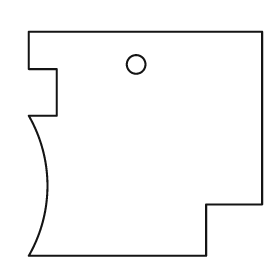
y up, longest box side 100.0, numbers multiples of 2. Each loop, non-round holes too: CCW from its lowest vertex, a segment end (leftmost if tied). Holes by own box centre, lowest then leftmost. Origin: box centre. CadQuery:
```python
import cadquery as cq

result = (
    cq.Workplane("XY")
    .moveTo(-50.0, -48.0)
    .lineTo(26.0, -48.0)
    .lineTo(26.0, -26.0)
    .lineTo(50.0, -26.0)
    .lineTo(50.0, 48.0)
    .lineTo(-50.0, 48.0)
    .lineTo(-50.0, 32.0)
    .lineTo(-38.0, 32.0)
    .lineTo(-38.0, 12.0)
    .lineTo(-50.0, 12.0)
    .threePointArc((-42.0, -18.0), (-50.0, -48.0))
    .close()
    .moveTo(-4.0, 34.0)
    .circle(4.0)
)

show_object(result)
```